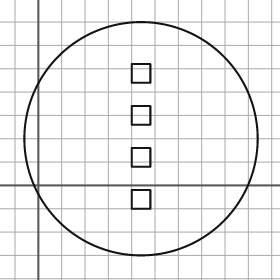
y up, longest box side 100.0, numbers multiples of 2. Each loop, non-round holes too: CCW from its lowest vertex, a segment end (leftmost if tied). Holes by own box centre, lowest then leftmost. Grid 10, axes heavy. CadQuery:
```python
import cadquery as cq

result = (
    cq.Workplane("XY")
    .moveTo(44.0, 20.0)
    .circle(50.0)
    .moveTo(40.0, -10.0)
    .lineTo(48.0, -10.0)
    .lineTo(48.0, -2.0)
    .lineTo(40.0, -2.0)
    .close()
    .moveTo(40.0, 8.0)
    .lineTo(48.0, 8.0)
    .lineTo(48.0, 16.0)
    .lineTo(40.0, 16.0)
    .close()
    .moveTo(40.0, 26.0)
    .lineTo(48.0, 26.0)
    .lineTo(48.0, 34.0)
    .lineTo(40.0, 34.0)
    .close()
    .moveTo(40.0, 44.0)
    .lineTo(48.0, 44.0)
    .lineTo(48.0, 52.0)
    .lineTo(40.0, 52.0)
    .close()
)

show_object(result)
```